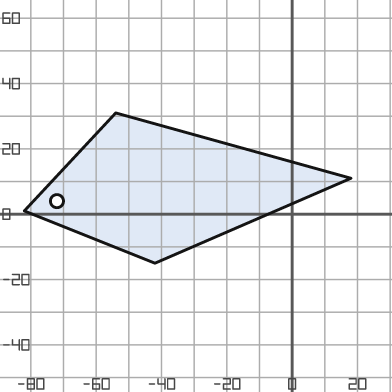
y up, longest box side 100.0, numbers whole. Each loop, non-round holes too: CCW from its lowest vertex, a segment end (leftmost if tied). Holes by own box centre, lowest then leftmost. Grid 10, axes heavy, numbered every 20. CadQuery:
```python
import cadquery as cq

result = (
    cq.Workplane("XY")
    .moveTo(-42.0, -15.0)
    .lineTo(18.0, 11.0)
    .lineTo(-54.0, 31.0)
    .lineTo(-82.0, 1.0)
    .close()
    .moveTo(-72.0, 4.0)
    .circle(2.0)
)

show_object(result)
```